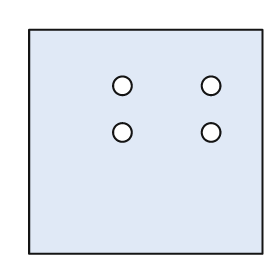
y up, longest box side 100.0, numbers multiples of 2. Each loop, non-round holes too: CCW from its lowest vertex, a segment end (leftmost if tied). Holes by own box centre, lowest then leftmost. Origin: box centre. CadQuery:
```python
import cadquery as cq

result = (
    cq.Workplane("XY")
    .moveTo(-50.0, -48.0)
    .lineTo(50.0, -48.0)
    .lineTo(50.0, 48.0)
    .lineTo(-50.0, 48.0)
    .close()
    .moveTo(-10.0, 4.0)
    .circle(4.0)
    .moveTo(28.0, 4.0)
    .circle(4.0)
    .moveTo(-10.0, 24.0)
    .circle(4.0)
    .moveTo(28.0, 24.0)
    .circle(4.0)
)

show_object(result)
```